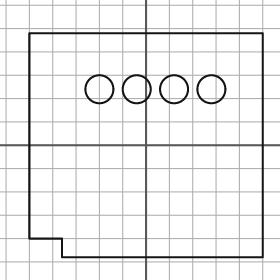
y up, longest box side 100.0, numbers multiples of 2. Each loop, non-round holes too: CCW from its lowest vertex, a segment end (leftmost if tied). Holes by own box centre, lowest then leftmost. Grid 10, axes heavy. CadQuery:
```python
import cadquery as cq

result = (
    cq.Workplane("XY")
    .moveTo(-36.0, -48.0)
    .lineTo(50.0, -48.0)
    .lineTo(50.0, 48.0)
    .lineTo(-50.0, 48.0)
    .lineTo(-50.0, -40.0)
    .lineTo(-36.0, -40.0)
    .close()
    .moveTo(-20.0, 24.0)
    .circle(6.0)
    .moveTo(-4.0, 24.0)
    .circle(6.0)
    .moveTo(12.0, 24.0)
    .circle(6.0)
    .moveTo(28.0, 24.0)
    .circle(6.0)
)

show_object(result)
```